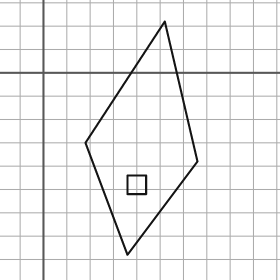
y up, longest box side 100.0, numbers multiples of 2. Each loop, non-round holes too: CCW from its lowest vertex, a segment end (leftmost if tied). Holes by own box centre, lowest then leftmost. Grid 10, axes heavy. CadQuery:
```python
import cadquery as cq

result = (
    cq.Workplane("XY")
    .moveTo(36.0, -78.0)
    .lineTo(66.0, -38.0)
    .lineTo(52.0, 22.0)
    .lineTo(18.0, -30.0)
    .close()
    .moveTo(36.0, -52.0)
    .lineTo(44.0, -52.0)
    .lineTo(44.0, -44.0)
    .lineTo(36.0, -44.0)
    .close()
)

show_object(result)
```